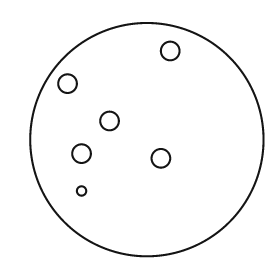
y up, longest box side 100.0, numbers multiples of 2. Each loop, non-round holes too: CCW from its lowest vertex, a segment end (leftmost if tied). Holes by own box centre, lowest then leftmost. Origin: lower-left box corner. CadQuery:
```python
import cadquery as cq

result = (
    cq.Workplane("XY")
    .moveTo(50.0, 50.0)
    .circle(50.0)
    .moveTo(22.0, 28.0)
    .circle(2.0)
    .moveTo(56.0, 42.0)
    .circle(4.0)
    .moveTo(22.0, 44.0)
    .circle(4.0)
    .moveTo(34.0, 58.0)
    .circle(4.0)
    .moveTo(16.0, 74.0)
    .circle(4.0)
    .moveTo(60.0, 88.0)
    .circle(4.0)
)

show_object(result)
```